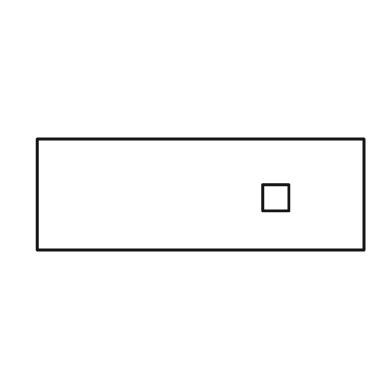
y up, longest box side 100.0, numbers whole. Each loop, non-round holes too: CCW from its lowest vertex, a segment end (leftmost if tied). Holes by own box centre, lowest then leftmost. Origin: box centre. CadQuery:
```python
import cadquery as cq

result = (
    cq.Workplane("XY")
    .moveTo(-50.0, -17.0)
    .lineTo(50.0, -17.0)
    .lineTo(50.0, 17.0)
    .lineTo(-50.0, 17.0)
    .close()
    .moveTo(19.0, -5.0)
    .lineTo(27.0, -5.0)
    .lineTo(27.0, 3.0)
    .lineTo(19.0, 3.0)
    .close()
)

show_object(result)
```